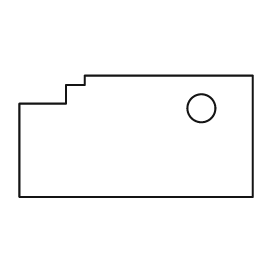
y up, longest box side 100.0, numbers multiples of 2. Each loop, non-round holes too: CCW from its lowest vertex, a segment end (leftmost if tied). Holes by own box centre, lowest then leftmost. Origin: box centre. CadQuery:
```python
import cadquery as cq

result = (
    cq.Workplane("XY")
    .moveTo(-50.0, -26.0)
    .lineTo(50.0, -26.0)
    .lineTo(50.0, 26.0)
    .lineTo(-22.0, 26.0)
    .lineTo(-22.0, 22.0)
    .lineTo(-30.0, 22.0)
    .lineTo(-30.0, 14.0)
    .lineTo(-50.0, 14.0)
    .close()
    .moveTo(28.0, 12.0)
    .circle(6.0)
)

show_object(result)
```